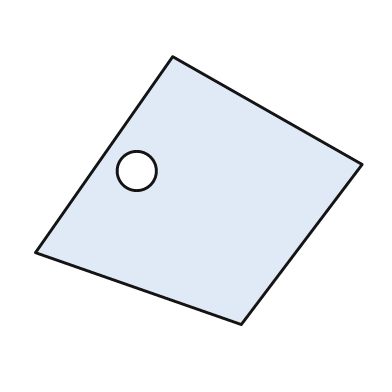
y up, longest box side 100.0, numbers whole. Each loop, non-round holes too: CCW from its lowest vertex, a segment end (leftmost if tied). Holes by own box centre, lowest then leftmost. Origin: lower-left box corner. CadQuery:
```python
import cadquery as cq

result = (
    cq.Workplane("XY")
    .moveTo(63.0, 0.0)
    .lineTo(100.0, 49.0)
    .lineTo(42.0, 82.0)
    .lineTo(0.0, 22.0)
    .close()
    .moveTo(31.0, 47.0)
    .circle(6.0)
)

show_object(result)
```